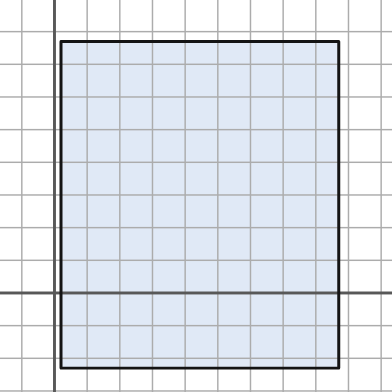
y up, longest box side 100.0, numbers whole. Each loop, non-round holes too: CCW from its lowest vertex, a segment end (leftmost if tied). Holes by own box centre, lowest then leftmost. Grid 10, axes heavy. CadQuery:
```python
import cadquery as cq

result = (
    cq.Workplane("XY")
    .moveTo(2.0, -23.0)
    .lineTo(87.0, -23.0)
    .lineTo(87.0, 77.0)
    .lineTo(2.0, 77.0)
    .close()
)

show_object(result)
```